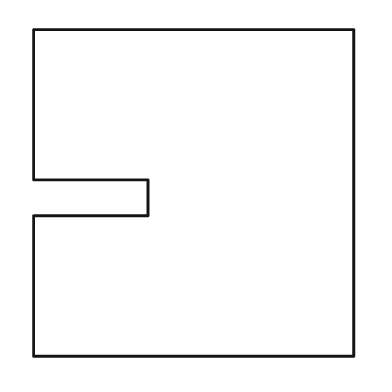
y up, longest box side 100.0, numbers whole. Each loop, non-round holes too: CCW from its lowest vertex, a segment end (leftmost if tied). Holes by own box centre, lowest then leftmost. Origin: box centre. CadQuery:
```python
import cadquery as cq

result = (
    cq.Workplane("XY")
    .moveTo(-49.0, -50.0)
    .lineTo(49.0, -50.0)
    .lineTo(49.0, 50.0)
    .lineTo(-49.0, 50.0)
    .lineTo(-49.0, 4.0)
    .lineTo(-14.0, 4.0)
    .lineTo(-14.0, -7.0)
    .lineTo(-49.0, -7.0)
    .close()
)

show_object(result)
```